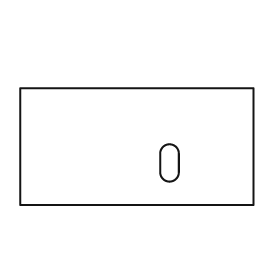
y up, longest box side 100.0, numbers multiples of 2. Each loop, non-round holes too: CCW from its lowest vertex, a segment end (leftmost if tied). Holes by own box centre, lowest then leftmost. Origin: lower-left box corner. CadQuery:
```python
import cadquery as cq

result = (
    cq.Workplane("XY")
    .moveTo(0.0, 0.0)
    .lineTo(100.0, 0.0)
    .lineTo(100.0, 50.0)
    .lineTo(0.0, 50.0)
    .close()
    .moveTo(60.0, 14.0)
    .threePointArc((64.0, 10.0), (68.0, 14.0))
    .lineTo(68.0, 22.0)
    .threePointArc((64.0, 26.0), (60.0, 22.0))
    .close()
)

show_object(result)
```